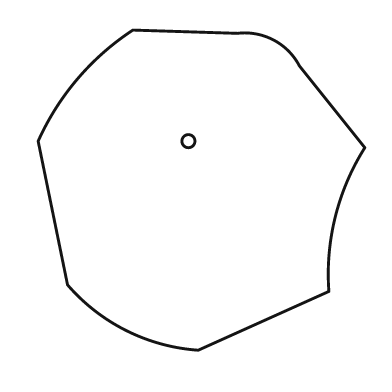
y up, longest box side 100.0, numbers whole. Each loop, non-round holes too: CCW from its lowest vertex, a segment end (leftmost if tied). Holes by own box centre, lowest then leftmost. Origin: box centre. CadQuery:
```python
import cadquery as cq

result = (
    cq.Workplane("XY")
    .moveTo(-1.0, -49.0)
    .lineTo(39.0, -31.0)
    .threePointArc((41.0, -8.0), (50.0, 13.0))
    .lineTo(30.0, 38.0)
    .threePointArc((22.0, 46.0), (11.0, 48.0))
    .lineTo(-21.0, 49.0)
    .threePointArc((-38.0, 34.0), (-50.0, 15.0))
    .lineTo(-41.0, -29.0)
    .threePointArc((-23.0, -43.0), (-1.0, -49.0))
    .close()
    .moveTo(-4.0, 15.0)
    .circle(2.0)
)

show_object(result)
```